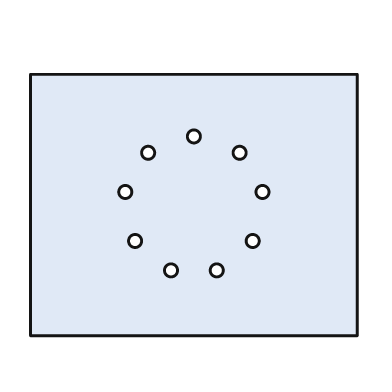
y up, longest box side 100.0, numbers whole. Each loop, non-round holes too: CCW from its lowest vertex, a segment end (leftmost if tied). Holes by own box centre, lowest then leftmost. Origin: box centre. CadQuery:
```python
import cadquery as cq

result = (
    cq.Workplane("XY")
    .moveTo(-50.0, -40.0)
    .lineTo(50.0, -40.0)
    .lineTo(50.0, 40.0)
    .lineTo(-50.0, 40.0)
    .close()
    .moveTo(-7.0, -20.0)
    .circle(2.0)
    .moveTo(7.0, -20.0)
    .circle(2.0)
    .moveTo(-18.0, -11.0)
    .circle(2.0)
    .moveTo(18.0, -11.0)
    .circle(2.0)
    .moveTo(-21.0, 4.0)
    .circle(2.0)
    .moveTo(21.0, 4.0)
    .circle(2.0)
    .moveTo(-14.0, 16.0)
    .circle(2.0)
    .moveTo(14.0, 16.0)
    .circle(2.0)
    .moveTo(0.0, 21.0)
    .circle(2.0)
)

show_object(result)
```